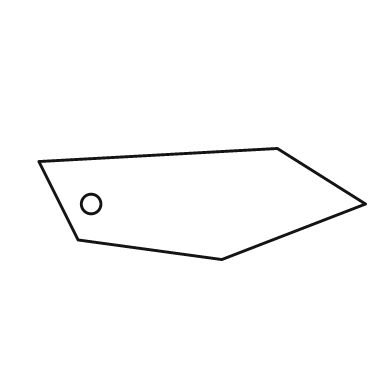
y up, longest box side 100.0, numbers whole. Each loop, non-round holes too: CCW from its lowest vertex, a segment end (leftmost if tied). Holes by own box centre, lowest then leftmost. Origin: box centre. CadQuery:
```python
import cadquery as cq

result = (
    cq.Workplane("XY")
    .moveTo(6.0, -17.0)
    .lineTo(50.0, 0.0)
    .lineTo(23.0, 17.0)
    .lineTo(-50.0, 13.0)
    .lineTo(-38.0, -11.0)
    .close()
    .moveTo(-34.0, 0.0)
    .circle(3.0)
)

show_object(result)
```